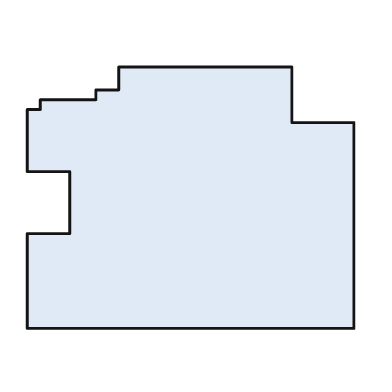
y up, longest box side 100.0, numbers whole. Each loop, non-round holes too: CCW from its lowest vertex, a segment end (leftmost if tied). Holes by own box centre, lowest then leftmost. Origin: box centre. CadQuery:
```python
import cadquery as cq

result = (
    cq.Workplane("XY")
    .moveTo(-50.0, -40.0)
    .lineTo(50.0, -40.0)
    .lineTo(50.0, 23.0)
    .lineTo(31.0, 23.0)
    .lineTo(31.0, 40.0)
    .lineTo(-22.0, 40.0)
    .lineTo(-22.0, 33.0)
    .lineTo(-29.0, 33.0)
    .lineTo(-29.0, 30.0)
    .lineTo(-46.0, 30.0)
    .lineTo(-46.0, 27.0)
    .lineTo(-50.0, 27.0)
    .lineTo(-50.0, 8.0)
    .lineTo(-37.0, 8.0)
    .lineTo(-37.0, -11.0)
    .lineTo(-50.0, -11.0)
    .close()
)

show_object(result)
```